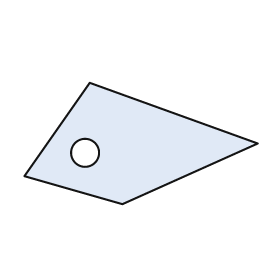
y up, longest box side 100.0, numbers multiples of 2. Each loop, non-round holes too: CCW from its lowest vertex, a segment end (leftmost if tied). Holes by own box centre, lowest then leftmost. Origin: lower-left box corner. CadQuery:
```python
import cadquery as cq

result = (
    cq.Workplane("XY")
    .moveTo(42.0, 0.0)
    .lineTo(100.0, 26.0)
    .lineTo(28.0, 52.0)
    .lineTo(0.0, 12.0)
    .close()
    .moveTo(26.0, 22.0)
    .circle(6.0)
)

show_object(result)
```